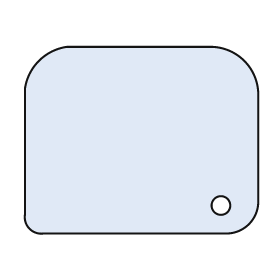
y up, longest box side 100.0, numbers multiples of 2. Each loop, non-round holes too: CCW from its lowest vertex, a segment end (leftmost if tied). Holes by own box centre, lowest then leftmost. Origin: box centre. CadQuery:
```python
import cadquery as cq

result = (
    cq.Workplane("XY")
    .moveTo(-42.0, -40.0)
    .lineTo(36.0, -40.0)
    .threePointArc((46.0, -36.0), (50.0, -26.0))
    .lineTo(50.0, 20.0)
    .threePointArc((44.0, 34.0), (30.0, 40.0))
    .lineTo(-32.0, 40.0)
    .threePointArc((-44.0, 34.0), (-50.0, 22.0))
    .lineTo(-50.0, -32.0)
    .threePointArc((-48.0, -38.0), (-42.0, -40.0))
    .close()
    .moveTo(34.0, -28.0)
    .circle(4.0)
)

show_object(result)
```